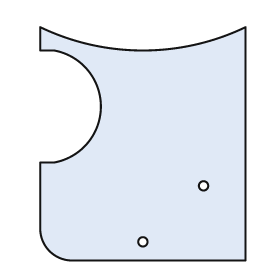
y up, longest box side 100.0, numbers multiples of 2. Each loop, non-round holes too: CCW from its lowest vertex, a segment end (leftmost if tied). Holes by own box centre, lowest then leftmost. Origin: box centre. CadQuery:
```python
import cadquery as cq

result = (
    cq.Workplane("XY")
    .moveTo(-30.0, -50.0)
    .lineTo(44.0, -50.0)
    .lineTo(44.0, 50.0)
    .threePointArc((0.0, 40.0), (-44.0, 50.0))
    .lineTo(-44.0, 40.0)
    .lineTo(-38.0, 40.0)
    .threePointArc((-18.0, 16.0), (-38.0, -8.0))
    .lineTo(-44.0, -8.0)
    .lineTo(-44.0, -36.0)
    .threePointArc((-40.0, -46.0), (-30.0, -50.0))
    .close()
    .moveTo(0.0, -42.0)
    .circle(2.0)
    .moveTo(26.0, -18.0)
    .circle(2.0)
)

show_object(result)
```